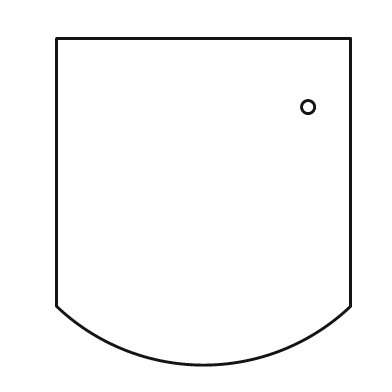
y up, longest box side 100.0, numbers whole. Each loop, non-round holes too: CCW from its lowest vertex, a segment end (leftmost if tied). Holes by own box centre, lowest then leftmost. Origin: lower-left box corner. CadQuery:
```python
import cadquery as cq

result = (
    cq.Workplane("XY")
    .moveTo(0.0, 18.0)
    .threePointArc((45.0, 0.0), (90.0, 18.0))
    .lineTo(90.0, 100.0)
    .lineTo(0.0, 100.0)
    .close()
    .moveTo(77.0, 79.0)
    .circle(2.0)
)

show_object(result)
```